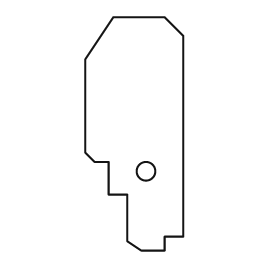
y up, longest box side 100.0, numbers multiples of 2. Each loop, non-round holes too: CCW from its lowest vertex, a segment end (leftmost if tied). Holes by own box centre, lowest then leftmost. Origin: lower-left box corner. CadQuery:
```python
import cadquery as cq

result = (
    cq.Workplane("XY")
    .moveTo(24.0, 0.0)
    .lineTo(34.0, 0.0)
    .lineTo(34.0, 6.0)
    .lineTo(42.0, 6.0)
    .lineTo(42.0, 92.0)
    .lineTo(34.0, 100.0)
    .lineTo(12.0, 100.0)
    .lineTo(0.0, 82.0)
    .lineTo(0.0, 42.0)
    .lineTo(4.0, 38.0)
    .lineTo(10.0, 38.0)
    .lineTo(10.0, 24.0)
    .lineTo(18.0, 24.0)
    .lineTo(18.0, 4.0)
    .close()
    .moveTo(26.0, 34.0)
    .circle(4.0)
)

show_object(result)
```